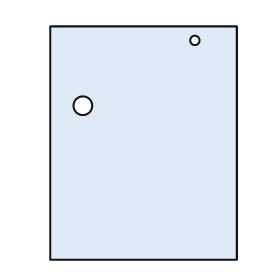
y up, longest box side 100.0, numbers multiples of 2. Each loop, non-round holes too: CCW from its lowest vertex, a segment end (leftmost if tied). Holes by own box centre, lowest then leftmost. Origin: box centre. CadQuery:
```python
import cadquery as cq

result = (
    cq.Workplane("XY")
    .moveTo(-40.0, -50.0)
    .lineTo(40.0, -50.0)
    .lineTo(40.0, 50.0)
    .lineTo(-40.0, 50.0)
    .close()
    .moveTo(-26.0, 16.0)
    .circle(4.0)
    .moveTo(22.0, 44.0)
    .circle(2.0)
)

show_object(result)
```